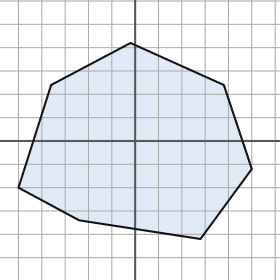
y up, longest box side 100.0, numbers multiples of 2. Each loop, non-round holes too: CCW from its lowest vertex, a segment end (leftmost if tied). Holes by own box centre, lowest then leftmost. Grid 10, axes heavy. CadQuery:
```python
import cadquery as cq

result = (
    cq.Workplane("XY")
    .moveTo(28.0, -42.0)
    .lineTo(50.0, -12.0)
    .lineTo(38.0, 24.0)
    .lineTo(-2.0, 42.0)
    .lineTo(-36.0, 24.0)
    .lineTo(-50.0, -20.0)
    .lineTo(-24.0, -34.0)
    .close()
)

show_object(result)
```